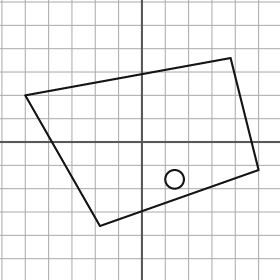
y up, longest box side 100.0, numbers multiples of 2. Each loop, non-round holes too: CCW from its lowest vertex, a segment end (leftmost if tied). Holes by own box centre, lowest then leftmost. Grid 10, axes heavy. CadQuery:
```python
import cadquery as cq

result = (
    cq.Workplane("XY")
    .moveTo(-18.0, -36.0)
    .lineTo(50.0, -12.0)
    .lineTo(38.0, 36.0)
    .lineTo(-50.0, 20.0)
    .close()
    .moveTo(14.0, -16.0)
    .circle(4.0)
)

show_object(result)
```